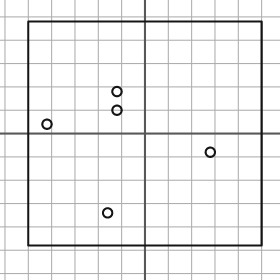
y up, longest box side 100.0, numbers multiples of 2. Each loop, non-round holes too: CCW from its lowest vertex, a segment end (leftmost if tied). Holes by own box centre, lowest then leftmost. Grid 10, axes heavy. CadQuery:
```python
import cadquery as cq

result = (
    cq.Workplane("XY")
    .moveTo(-50.0, -48.0)
    .lineTo(50.0, -48.0)
    .lineTo(50.0, 48.0)
    .lineTo(-50.0, 48.0)
    .close()
    .moveTo(-16.0, -34.0)
    .circle(2.0)
    .moveTo(28.0, -8.0)
    .circle(2.0)
    .moveTo(-42.0, 4.0)
    .circle(2.0)
    .moveTo(-12.0, 10.0)
    .circle(2.0)
    .moveTo(-12.0, 18.0)
    .circle(2.0)
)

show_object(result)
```